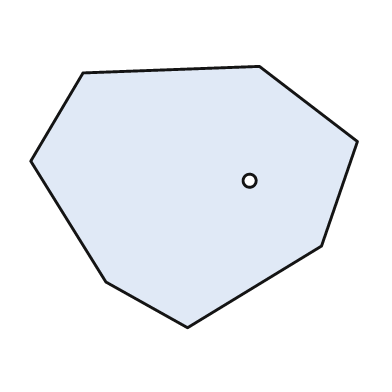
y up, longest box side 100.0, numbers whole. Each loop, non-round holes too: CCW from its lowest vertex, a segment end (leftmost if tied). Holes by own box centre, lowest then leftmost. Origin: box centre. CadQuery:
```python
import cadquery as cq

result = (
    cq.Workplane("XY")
    .moveTo(-2.0, -40.0)
    .lineTo(39.0, -15.0)
    .lineTo(50.0, 17.0)
    .lineTo(20.0, 40.0)
    .lineTo(-34.0, 38.0)
    .lineTo(-50.0, 11.0)
    .lineTo(-27.0, -26.0)
    .close()
    .moveTo(17.0, 5.0)
    .circle(2.0)
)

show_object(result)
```